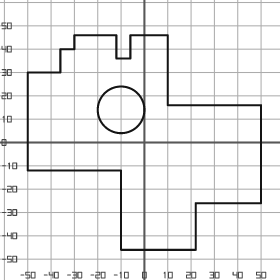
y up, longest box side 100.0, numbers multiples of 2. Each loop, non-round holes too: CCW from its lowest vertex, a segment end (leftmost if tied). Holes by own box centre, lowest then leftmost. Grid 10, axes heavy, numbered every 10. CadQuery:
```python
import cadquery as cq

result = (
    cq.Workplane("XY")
    .moveTo(-10.0, -46.0)
    .lineTo(22.0, -46.0)
    .lineTo(22.0, -26.0)
    .lineTo(50.0, -26.0)
    .lineTo(50.0, 16.0)
    .lineTo(10.0, 16.0)
    .lineTo(10.0, 46.0)
    .lineTo(-6.0, 46.0)
    .lineTo(-6.0, 36.0)
    .lineTo(-12.0, 36.0)
    .lineTo(-12.0, 46.0)
    .lineTo(-30.0, 46.0)
    .lineTo(-30.0, 40.0)
    .lineTo(-36.0, 40.0)
    .lineTo(-36.0, 30.0)
    .lineTo(-50.0, 30.0)
    .lineTo(-50.0, -12.0)
    .lineTo(-10.0, -12.0)
    .close()
    .moveTo(-10.0, 14.0)
    .circle(10.0)
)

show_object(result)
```